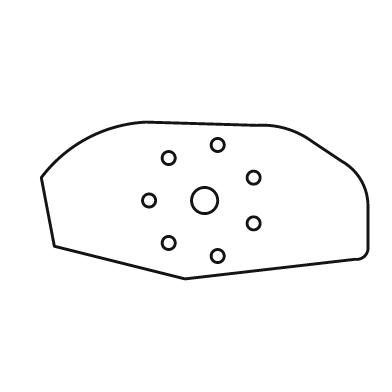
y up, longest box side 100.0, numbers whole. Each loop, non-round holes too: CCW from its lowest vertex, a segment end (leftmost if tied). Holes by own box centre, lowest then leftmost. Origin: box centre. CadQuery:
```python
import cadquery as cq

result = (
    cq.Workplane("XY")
    .moveTo(-6.0, -24.0)
    .lineTo(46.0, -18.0)
    .threePointArc((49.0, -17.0), (50.0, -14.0))
    .lineTo(50.0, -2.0)
    .threePointArc((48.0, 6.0), (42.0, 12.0))
    .lineTo(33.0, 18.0)
    .threePointArc((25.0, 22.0), (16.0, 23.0))
    .lineTo(-18.0, 24.0)
    .threePointArc((-36.0, 19.0), (-50.0, 7.0))
    .lineTo(-46.0, -14.0)
    .close()
    .moveTo(4.0, -17.0)
    .circle(2.0)
    .moveTo(-11.0, -13.0)
    .circle(2.0)
    .moveTo(15.0, -7.0)
    .circle(2.0)
    .moveTo(-17.0, 0.0)
    .circle(2.0)
    .moveTo(0.0, 0.0)
    .circle(4.0)
    .moveTo(15.0, 7.0)
    .circle(2.0)
    .moveTo(-11.0, 13.0)
    .circle(2.0)
    .moveTo(4.0, 17.0)
    .circle(2.0)
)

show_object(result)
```